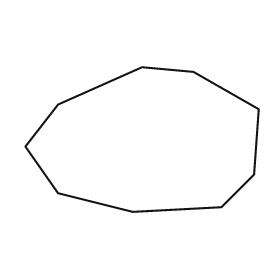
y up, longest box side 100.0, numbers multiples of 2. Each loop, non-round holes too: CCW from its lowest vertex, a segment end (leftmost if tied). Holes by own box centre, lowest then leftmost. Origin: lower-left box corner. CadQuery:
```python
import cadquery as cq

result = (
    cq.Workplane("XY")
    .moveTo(46.0, 0.0)
    .lineTo(84.0, 2.0)
    .lineTo(98.0, 16.0)
    .lineTo(100.0, 44.0)
    .lineTo(72.0, 60.0)
    .lineTo(50.0, 62.0)
    .lineTo(14.0, 46.0)
    .lineTo(0.0, 28.0)
    .lineTo(14.0, 8.0)
    .close()
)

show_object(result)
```